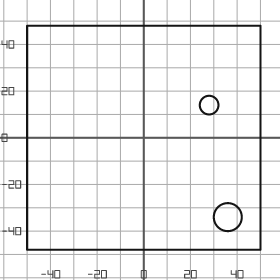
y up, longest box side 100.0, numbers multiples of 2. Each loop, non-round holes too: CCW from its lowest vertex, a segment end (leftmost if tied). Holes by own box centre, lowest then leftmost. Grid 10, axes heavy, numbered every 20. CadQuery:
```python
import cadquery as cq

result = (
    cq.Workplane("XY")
    .moveTo(-50.0, -48.0)
    .lineTo(50.0, -48.0)
    .lineTo(50.0, 48.0)
    .lineTo(-50.0, 48.0)
    .close()
    .moveTo(36.0, -34.0)
    .circle(6.0)
    .moveTo(28.0, 14.0)
    .circle(4.0)
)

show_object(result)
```